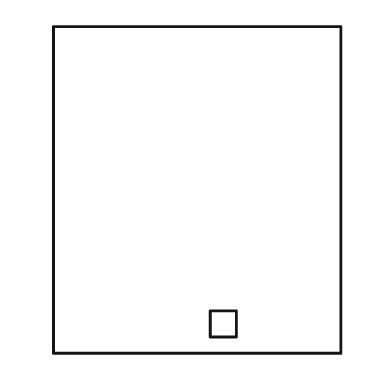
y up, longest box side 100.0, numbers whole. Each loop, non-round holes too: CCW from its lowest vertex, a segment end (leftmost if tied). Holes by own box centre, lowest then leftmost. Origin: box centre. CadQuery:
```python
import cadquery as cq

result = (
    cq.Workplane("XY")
    .moveTo(-44.0, -50.0)
    .lineTo(44.0, -50.0)
    .lineTo(44.0, 50.0)
    .lineTo(-44.0, 50.0)
    .close()
    .moveTo(4.0, -45.0)
    .lineTo(12.0, -45.0)
    .lineTo(12.0, -37.0)
    .lineTo(4.0, -37.0)
    .close()
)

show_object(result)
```